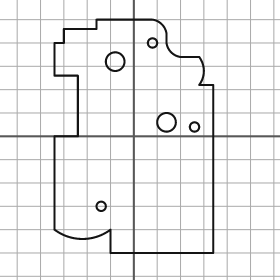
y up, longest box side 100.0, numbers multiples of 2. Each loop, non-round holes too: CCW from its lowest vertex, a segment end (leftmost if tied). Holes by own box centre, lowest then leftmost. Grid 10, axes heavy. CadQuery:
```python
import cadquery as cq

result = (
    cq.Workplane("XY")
    .moveTo(-10.0, -50.0)
    .lineTo(34.0, -50.0)
    .lineTo(34.0, 22.0)
    .lineTo(28.0, 22.0)
    .threePointArc((30.0, 28.0), (28.0, 34.0))
    .lineTo(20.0, 34.0)
    .threePointArc((16.0, 36.0), (14.0, 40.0))
    .lineTo(14.0, 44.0)
    .threePointArc((12.0, 48.0), (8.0, 50.0))
    .lineTo(-16.0, 50.0)
    .lineTo(-16.0, 46.0)
    .lineTo(-30.0, 46.0)
    .lineTo(-30.0, 40.0)
    .lineTo(-34.0, 40.0)
    .lineTo(-34.0, 26.0)
    .lineTo(-24.0, 26.0)
    .lineTo(-24.0, 0.0)
    .lineTo(-34.0, 0.0)
    .lineTo(-34.0, -40.0)
    .threePointArc((-22.0, -44.0), (-10.0, -40.0))
    .close()
    .moveTo(-14.0, -30.0)
    .circle(2.0)
    .moveTo(26.0, 4.0)
    .circle(2.0)
    .moveTo(14.0, 6.0)
    .circle(4.0)
    .moveTo(-8.0, 32.0)
    .circle(4.0)
    .moveTo(8.0, 40.0)
    .circle(2.0)
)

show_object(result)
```